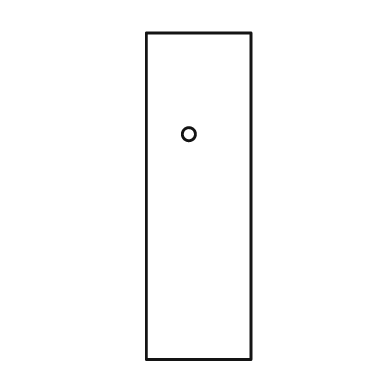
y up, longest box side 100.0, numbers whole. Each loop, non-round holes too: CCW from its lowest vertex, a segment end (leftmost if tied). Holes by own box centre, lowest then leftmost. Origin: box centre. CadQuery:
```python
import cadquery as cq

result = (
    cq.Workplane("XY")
    .moveTo(-16.0, -50.0)
    .lineTo(16.0, -50.0)
    .lineTo(16.0, 50.0)
    .lineTo(-16.0, 50.0)
    .close()
    .moveTo(-3.0, 19.0)
    .circle(2.0)
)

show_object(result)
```